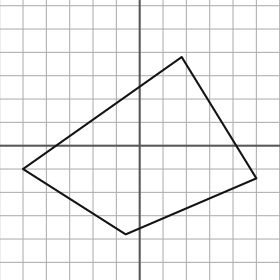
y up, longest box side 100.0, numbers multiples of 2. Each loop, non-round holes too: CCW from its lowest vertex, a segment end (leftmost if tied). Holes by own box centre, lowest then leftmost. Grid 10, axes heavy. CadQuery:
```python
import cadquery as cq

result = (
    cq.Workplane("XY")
    .moveTo(-6.0, -38.0)
    .lineTo(50.0, -14.0)
    .lineTo(18.0, 38.0)
    .lineTo(-50.0, -10.0)
    .close()
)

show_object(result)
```